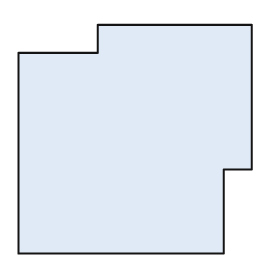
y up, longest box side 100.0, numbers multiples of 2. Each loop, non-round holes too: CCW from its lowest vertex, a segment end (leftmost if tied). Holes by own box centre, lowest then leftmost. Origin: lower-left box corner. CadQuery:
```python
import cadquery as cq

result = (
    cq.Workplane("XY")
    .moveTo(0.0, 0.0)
    .lineTo(88.0, 0.0)
    .lineTo(88.0, 36.0)
    .lineTo(100.0, 36.0)
    .lineTo(100.0, 98.0)
    .lineTo(34.0, 98.0)
    .lineTo(34.0, 86.0)
    .lineTo(0.0, 86.0)
    .close()
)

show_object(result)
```